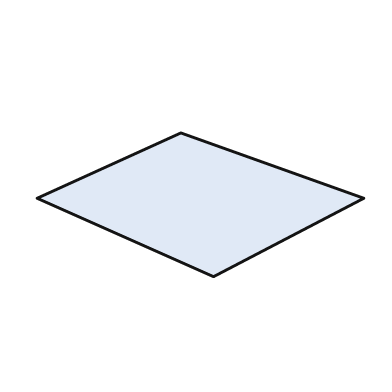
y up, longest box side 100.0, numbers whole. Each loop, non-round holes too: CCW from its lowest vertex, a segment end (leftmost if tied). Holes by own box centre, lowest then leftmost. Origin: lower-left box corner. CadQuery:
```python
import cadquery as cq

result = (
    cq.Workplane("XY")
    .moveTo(54.0, 0.0)
    .lineTo(100.0, 24.0)
    .lineTo(44.0, 44.0)
    .lineTo(0.0, 24.0)
    .close()
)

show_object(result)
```